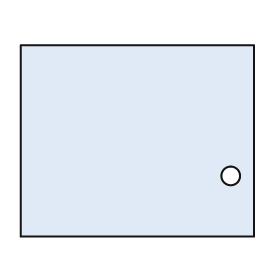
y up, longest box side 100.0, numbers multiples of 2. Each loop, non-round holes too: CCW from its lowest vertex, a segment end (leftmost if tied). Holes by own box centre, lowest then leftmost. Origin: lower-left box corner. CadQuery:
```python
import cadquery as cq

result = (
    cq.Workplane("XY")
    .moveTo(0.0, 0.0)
    .lineTo(100.0, 0.0)
    .lineTo(100.0, 82.0)
    .lineTo(0.0, 82.0)
    .close()
    .moveTo(90.0, 26.0)
    .circle(4.0)
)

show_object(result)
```